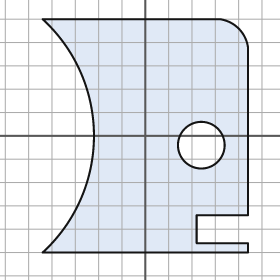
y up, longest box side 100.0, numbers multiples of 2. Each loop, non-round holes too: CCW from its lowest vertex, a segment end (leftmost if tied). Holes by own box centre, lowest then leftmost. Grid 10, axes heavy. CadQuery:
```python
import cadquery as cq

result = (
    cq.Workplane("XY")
    .moveTo(-44.0, -50.0)
    .lineTo(44.0, -50.0)
    .lineTo(44.0, -46.0)
    .lineTo(22.0, -46.0)
    .lineTo(22.0, -34.0)
    .lineTo(44.0, -34.0)
    .lineTo(44.0, 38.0)
    .threePointArc((40.0, 46.0), (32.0, 50.0))
    .lineTo(-44.0, 50.0)
    .threePointArc((-22.0, 0.0), (-44.0, -50.0))
    .close()
    .moveTo(24.0, -4.0)
    .circle(10.0)
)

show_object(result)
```